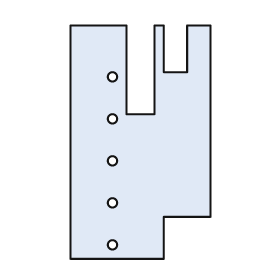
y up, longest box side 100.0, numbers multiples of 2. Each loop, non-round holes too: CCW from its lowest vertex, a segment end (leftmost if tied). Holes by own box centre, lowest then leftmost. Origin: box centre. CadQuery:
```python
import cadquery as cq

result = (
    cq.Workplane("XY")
    .moveTo(-30.0, -50.0)
    .lineTo(10.0, -50.0)
    .lineTo(10.0, -32.0)
    .lineTo(30.0, -32.0)
    .lineTo(30.0, 50.0)
    .lineTo(20.0, 50.0)
    .lineTo(20.0, 30.0)
    .lineTo(10.0, 30.0)
    .lineTo(10.0, 50.0)
    .lineTo(6.0, 50.0)
    .lineTo(6.0, 12.0)
    .lineTo(-6.0, 12.0)
    .lineTo(-6.0, 50.0)
    .lineTo(-30.0, 50.0)
    .close()
    .moveTo(-12.0, -44.0)
    .circle(2.0)
    .moveTo(-12.0, -26.0)
    .circle(2.0)
    .moveTo(-12.0, -8.0)
    .circle(2.0)
    .moveTo(-12.0, 10.0)
    .circle(2.0)
    .moveTo(-12.0, 28.0)
    .circle(2.0)
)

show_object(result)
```